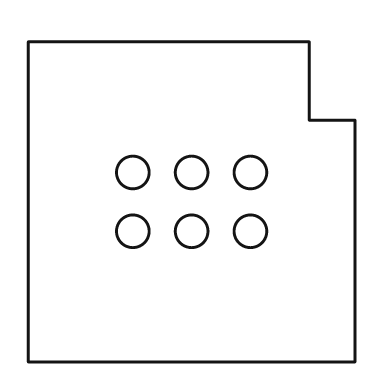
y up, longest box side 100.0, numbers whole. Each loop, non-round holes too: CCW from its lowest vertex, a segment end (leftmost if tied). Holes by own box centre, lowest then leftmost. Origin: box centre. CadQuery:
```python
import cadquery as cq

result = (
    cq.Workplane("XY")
    .moveTo(-50.0, -49.0)
    .lineTo(50.0, -49.0)
    .lineTo(50.0, 25.0)
    .lineTo(36.0, 25.0)
    .lineTo(36.0, 49.0)
    .lineTo(-50.0, 49.0)
    .close()
    .moveTo(-18.0, -9.0)
    .circle(5.0)
    .moveTo(0.0, -9.0)
    .circle(5.0)
    .moveTo(18.0, -9.0)
    .circle(5.0)
    .moveTo(-18.0, 9.0)
    .circle(5.0)
    .moveTo(0.0, 9.0)
    .circle(5.0)
    .moveTo(18.0, 9.0)
    .circle(5.0)
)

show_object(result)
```